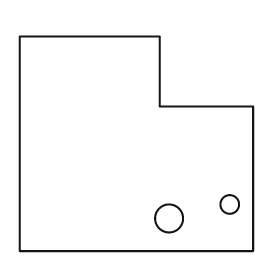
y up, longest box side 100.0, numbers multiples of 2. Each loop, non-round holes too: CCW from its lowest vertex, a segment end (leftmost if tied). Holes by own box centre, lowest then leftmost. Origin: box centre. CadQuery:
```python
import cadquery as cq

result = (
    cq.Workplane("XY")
    .moveTo(-50.0, -46.0)
    .lineTo(50.0, -46.0)
    .lineTo(50.0, 16.0)
    .lineTo(10.0, 16.0)
    .lineTo(10.0, 46.0)
    .lineTo(-50.0, 46.0)
    .close()
    .moveTo(14.0, -32.0)
    .circle(6.0)
    .moveTo(40.0, -26.0)
    .circle(4.0)
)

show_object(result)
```